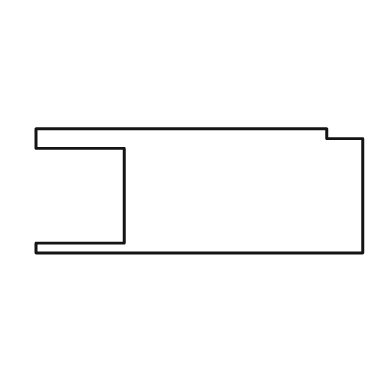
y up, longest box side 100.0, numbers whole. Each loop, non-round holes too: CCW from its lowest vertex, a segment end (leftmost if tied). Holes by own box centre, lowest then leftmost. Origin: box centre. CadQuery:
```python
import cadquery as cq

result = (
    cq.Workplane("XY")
    .moveTo(-50.0, -19.0)
    .lineTo(50.0, -19.0)
    .lineTo(50.0, 16.0)
    .lineTo(39.0, 16.0)
    .lineTo(39.0, 19.0)
    .lineTo(-50.0, 19.0)
    .lineTo(-50.0, 13.0)
    .lineTo(-23.0, 13.0)
    .lineTo(-23.0, -16.0)
    .lineTo(-50.0, -16.0)
    .close()
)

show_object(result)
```